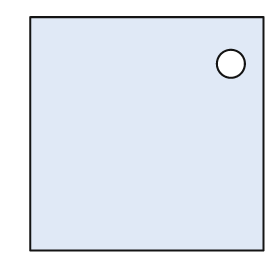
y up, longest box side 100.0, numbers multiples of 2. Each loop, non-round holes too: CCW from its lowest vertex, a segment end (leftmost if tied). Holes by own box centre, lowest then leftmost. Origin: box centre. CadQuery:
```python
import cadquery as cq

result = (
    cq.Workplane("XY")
    .moveTo(-50.0, -50.0)
    .lineTo(50.0, -50.0)
    .lineTo(50.0, 50.0)
    .lineTo(-50.0, 50.0)
    .close()
    .moveTo(36.0, 30.0)
    .circle(6.0)
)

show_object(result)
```